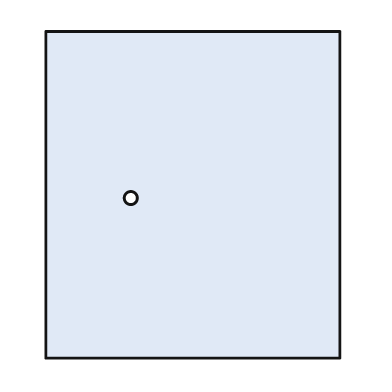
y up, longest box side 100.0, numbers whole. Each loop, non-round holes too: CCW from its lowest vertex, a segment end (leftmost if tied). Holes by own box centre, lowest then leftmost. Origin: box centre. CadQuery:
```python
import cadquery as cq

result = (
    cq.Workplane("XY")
    .moveTo(-45.0, -50.0)
    .lineTo(45.0, -50.0)
    .lineTo(45.0, 50.0)
    .lineTo(-45.0, 50.0)
    .close()
    .moveTo(-19.0, -1.0)
    .circle(2.0)
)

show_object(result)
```